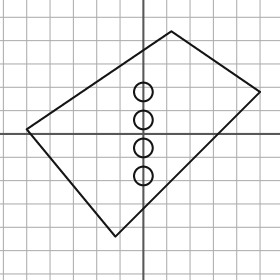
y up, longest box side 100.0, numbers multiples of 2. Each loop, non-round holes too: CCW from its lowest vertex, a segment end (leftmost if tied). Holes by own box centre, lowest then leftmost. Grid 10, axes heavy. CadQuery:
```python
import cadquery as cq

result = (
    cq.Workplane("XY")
    .moveTo(-12.0, -44.0)
    .lineTo(50.0, 18.0)
    .lineTo(12.0, 44.0)
    .lineTo(-50.0, 2.0)
    .close()
    .moveTo(0.0, -18.0)
    .circle(4.0)
    .moveTo(0.0, -6.0)
    .circle(4.0)
    .moveTo(0.0, 6.0)
    .circle(4.0)
    .moveTo(0.0, 18.0)
    .circle(4.0)
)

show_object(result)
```